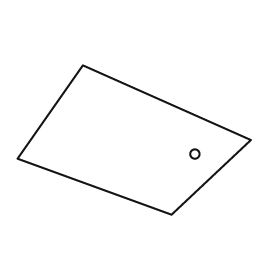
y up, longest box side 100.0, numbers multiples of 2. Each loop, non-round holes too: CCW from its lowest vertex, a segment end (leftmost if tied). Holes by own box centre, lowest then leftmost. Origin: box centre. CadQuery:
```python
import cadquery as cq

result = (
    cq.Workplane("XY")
    .moveTo(16.0, -32.0)
    .lineTo(50.0, 0.0)
    .lineTo(-22.0, 32.0)
    .lineTo(-50.0, -8.0)
    .close()
    .moveTo(26.0, -6.0)
    .circle(2.0)
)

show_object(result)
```